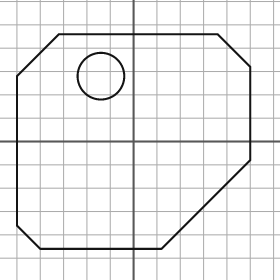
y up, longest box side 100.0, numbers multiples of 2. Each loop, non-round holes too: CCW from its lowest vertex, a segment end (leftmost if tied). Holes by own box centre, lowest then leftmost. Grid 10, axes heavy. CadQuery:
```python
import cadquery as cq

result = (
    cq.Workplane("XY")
    .moveTo(-40.0, -46.0)
    .lineTo(12.0, -46.0)
    .lineTo(50.0, -8.0)
    .lineTo(50.0, 32.0)
    .lineTo(36.0, 46.0)
    .lineTo(-32.0, 46.0)
    .lineTo(-50.0, 28.0)
    .lineTo(-50.0, -36.0)
    .close()
    .moveTo(-14.0, 28.0)
    .circle(10.0)
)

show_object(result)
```